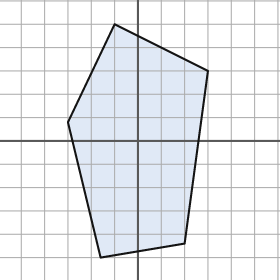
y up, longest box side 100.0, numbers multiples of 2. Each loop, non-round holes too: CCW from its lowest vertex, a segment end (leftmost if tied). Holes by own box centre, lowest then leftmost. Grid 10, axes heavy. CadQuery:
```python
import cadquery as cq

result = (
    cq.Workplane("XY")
    .moveTo(-16.0, -50.0)
    .lineTo(20.0, -44.0)
    .lineTo(30.0, 30.0)
    .lineTo(-10.0, 50.0)
    .lineTo(-30.0, 8.0)
    .close()
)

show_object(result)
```